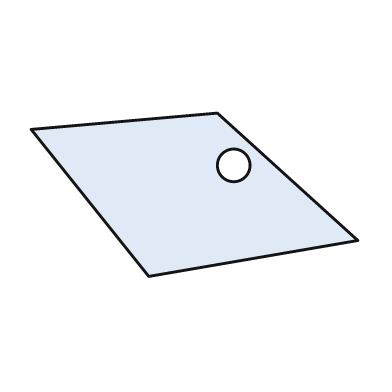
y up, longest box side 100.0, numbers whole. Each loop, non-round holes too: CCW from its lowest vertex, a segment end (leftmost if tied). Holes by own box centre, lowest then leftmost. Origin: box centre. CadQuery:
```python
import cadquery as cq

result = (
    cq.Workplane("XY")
    .moveTo(-14.0, -25.0)
    .lineTo(50.0, -14.0)
    .lineTo(7.0, 25.0)
    .lineTo(-50.0, 20.0)
    .close()
    .moveTo(12.0, 9.0)
    .circle(5.0)
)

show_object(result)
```